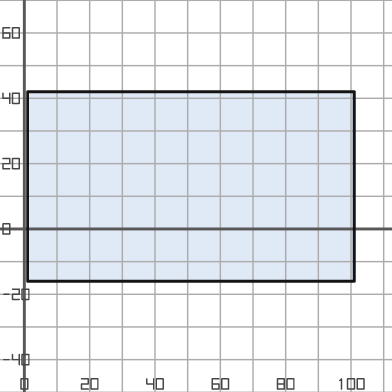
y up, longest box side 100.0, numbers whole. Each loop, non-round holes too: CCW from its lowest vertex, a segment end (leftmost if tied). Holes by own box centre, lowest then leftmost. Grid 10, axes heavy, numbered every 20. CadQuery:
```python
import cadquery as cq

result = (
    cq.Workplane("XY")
    .moveTo(1.0, -16.0)
    .lineTo(101.0, -16.0)
    .lineTo(101.0, 42.0)
    .lineTo(1.0, 42.0)
    .close()
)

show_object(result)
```